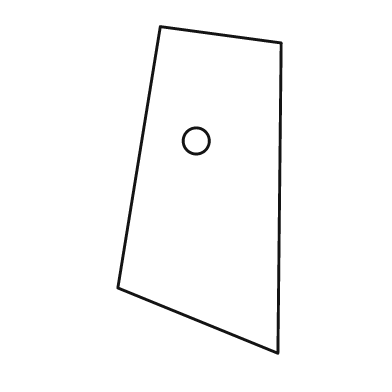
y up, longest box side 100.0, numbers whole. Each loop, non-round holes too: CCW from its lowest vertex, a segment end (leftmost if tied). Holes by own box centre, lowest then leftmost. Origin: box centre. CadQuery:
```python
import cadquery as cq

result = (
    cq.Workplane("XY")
    .moveTo(24.0, -50.0)
    .lineTo(25.0, 45.0)
    .lineTo(-12.0, 50.0)
    .lineTo(-25.0, -30.0)
    .close()
    .moveTo(-1.0, 15.0)
    .circle(4.0)
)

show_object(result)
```